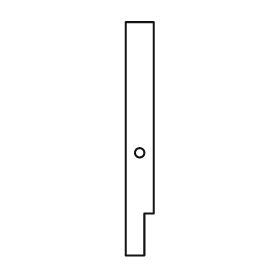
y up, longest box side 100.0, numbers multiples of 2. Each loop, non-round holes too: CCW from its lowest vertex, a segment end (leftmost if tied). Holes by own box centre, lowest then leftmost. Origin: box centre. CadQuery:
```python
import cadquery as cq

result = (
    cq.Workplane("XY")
    .moveTo(-6.0, -50.0)
    .lineTo(2.0, -50.0)
    .lineTo(2.0, -32.0)
    .lineTo(6.0, -32.0)
    .lineTo(6.0, 50.0)
    .lineTo(-6.0, 50.0)
    .close()
    .moveTo(0.0, -6.0)
    .circle(2.0)
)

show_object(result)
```